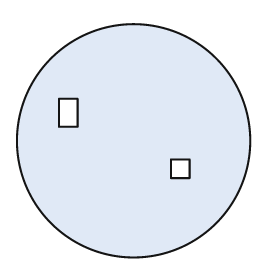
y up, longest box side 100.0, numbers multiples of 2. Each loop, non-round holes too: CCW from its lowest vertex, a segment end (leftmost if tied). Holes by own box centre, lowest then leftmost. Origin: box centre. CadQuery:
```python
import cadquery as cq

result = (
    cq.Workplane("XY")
    .moveTo(0.0, 0.0)
    .circle(50.0)
    .moveTo(16.0, -16.0)
    .lineTo(24.0, -16.0)
    .lineTo(24.0, -8.0)
    .lineTo(16.0, -8.0)
    .close()
    .moveTo(-32.0, 6.0)
    .lineTo(-24.0, 6.0)
    .lineTo(-24.0, 18.0)
    .lineTo(-32.0, 18.0)
    .close()
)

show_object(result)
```